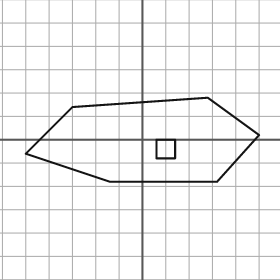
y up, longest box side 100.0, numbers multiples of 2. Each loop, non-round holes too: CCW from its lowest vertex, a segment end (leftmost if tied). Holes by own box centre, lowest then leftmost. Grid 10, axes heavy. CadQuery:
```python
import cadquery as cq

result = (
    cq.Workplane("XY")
    .moveTo(-14.0, -18.0)
    .lineTo(32.0, -18.0)
    .lineTo(50.0, 2.0)
    .lineTo(28.0, 18.0)
    .lineTo(-30.0, 14.0)
    .lineTo(-50.0, -6.0)
    .close()
    .moveTo(6.0, -8.0)
    .lineTo(14.0, -8.0)
    .lineTo(14.0, 0.0)
    .lineTo(6.0, 0.0)
    .close()
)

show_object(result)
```